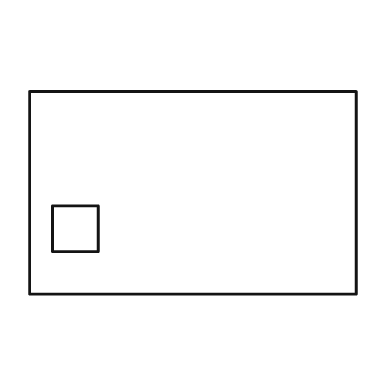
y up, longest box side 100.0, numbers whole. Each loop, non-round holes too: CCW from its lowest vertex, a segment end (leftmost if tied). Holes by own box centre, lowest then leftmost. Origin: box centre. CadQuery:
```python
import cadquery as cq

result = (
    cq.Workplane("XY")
    .moveTo(-50.0, -31.0)
    .lineTo(50.0, -31.0)
    .lineTo(50.0, 31.0)
    .lineTo(-50.0, 31.0)
    .close()
    .moveTo(-43.0, -18.0)
    .lineTo(-29.0, -18.0)
    .lineTo(-29.0, -4.0)
    .lineTo(-43.0, -4.0)
    .close()
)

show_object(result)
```